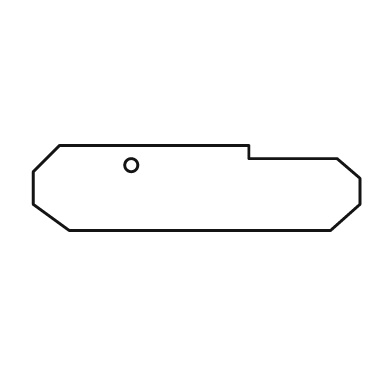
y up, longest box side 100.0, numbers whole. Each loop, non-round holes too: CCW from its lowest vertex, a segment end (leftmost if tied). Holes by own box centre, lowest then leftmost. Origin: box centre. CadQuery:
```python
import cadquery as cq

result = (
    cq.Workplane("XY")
    .moveTo(-39.0, -13.0)
    .lineTo(41.0, -13.0)
    .lineTo(50.0, -5.0)
    .lineTo(50.0, 3.0)
    .lineTo(43.0, 9.0)
    .lineTo(16.0, 9.0)
    .lineTo(16.0, 13.0)
    .lineTo(-42.0, 13.0)
    .lineTo(-50.0, 5.0)
    .lineTo(-50.0, -5.0)
    .close()
    .moveTo(-20.0, 7.0)
    .circle(2.0)
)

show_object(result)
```